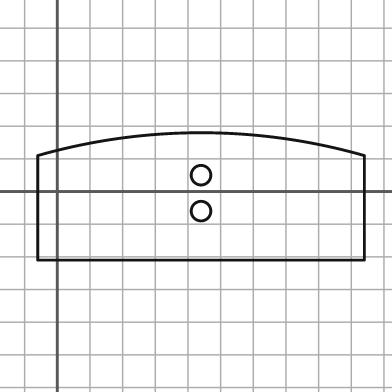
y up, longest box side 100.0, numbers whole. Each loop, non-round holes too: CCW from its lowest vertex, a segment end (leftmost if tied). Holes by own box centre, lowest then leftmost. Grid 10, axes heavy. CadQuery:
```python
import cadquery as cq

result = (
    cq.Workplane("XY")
    .moveTo(-6.0, -21.0)
    .lineTo(94.0, -21.0)
    .lineTo(94.0, 11.0)
    .threePointArc((44.0, 18.0), (-6.0, 11.0))
    .close()
    .moveTo(44.0, -6.0)
    .circle(3.0)
    .moveTo(44.0, 5.0)
    .circle(3.0)
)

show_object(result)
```